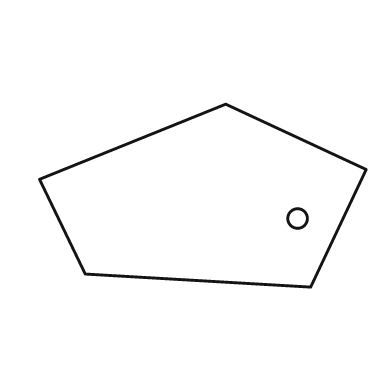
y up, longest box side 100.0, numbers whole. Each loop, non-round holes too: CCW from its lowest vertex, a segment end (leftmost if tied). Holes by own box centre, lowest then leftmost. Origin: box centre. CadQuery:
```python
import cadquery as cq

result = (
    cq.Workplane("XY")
    .moveTo(33.0, -28.0)
    .lineTo(50.0, 8.0)
    .lineTo(7.0, 28.0)
    .lineTo(-50.0, 5.0)
    .lineTo(-36.0, -24.0)
    .close()
    .moveTo(29.0, -7.0)
    .circle(3.0)
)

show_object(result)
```